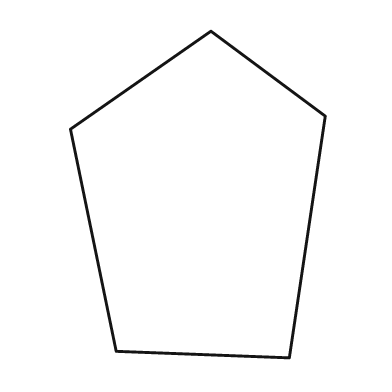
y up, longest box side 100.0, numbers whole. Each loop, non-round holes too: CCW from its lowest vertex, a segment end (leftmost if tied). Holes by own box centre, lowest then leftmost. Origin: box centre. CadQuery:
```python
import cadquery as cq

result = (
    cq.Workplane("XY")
    .moveTo(28.0, -50.0)
    .lineTo(39.0, 24.0)
    .lineTo(4.0, 50.0)
    .lineTo(-39.0, 20.0)
    .lineTo(-25.0, -48.0)
    .close()
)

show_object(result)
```